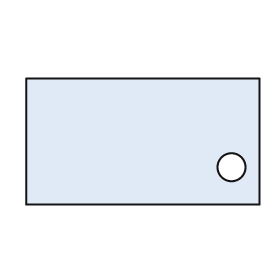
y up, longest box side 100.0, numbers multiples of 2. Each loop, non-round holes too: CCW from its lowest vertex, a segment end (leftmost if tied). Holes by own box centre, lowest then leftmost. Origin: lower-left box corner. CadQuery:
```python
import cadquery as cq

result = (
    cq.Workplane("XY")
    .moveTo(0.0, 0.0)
    .lineTo(100.0, 0.0)
    .lineTo(100.0, 54.0)
    .lineTo(0.0, 54.0)
    .close()
    .moveTo(88.0, 16.0)
    .circle(6.0)
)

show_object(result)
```